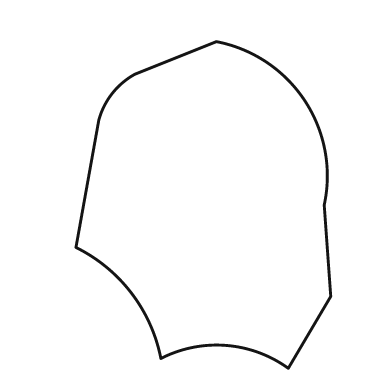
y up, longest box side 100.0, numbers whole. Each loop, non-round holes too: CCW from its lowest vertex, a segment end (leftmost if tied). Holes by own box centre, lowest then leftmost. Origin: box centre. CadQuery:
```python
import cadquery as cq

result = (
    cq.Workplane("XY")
    .moveTo(26.0, -50.0)
    .lineTo(39.0, -28.0)
    .lineTo(37.0, 0.0)
    .threePointArc((31.0, 32.0), (4.0, 50.0))
    .lineTo(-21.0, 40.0)
    .threePointArc((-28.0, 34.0), (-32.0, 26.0))
    .lineTo(-39.0, -13.0)
    .threePointArc((-22.0, -27.0), (-13.0, -47.0))
    .threePointArc((7.0, -43.0), (26.0, -50.0))
    .close()
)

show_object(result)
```